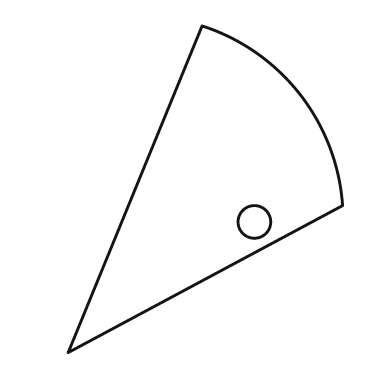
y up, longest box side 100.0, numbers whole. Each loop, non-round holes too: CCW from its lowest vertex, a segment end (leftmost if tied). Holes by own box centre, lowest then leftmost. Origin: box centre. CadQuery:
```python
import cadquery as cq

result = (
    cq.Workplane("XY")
    .moveTo(-42.0, -50.0)
    .lineTo(42.0, -5.0)
    .threePointArc((29.0, 29.0), (-1.0, 50.0))
    .close()
    .moveTo(15.0, -10.0)
    .circle(5.0)
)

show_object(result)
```